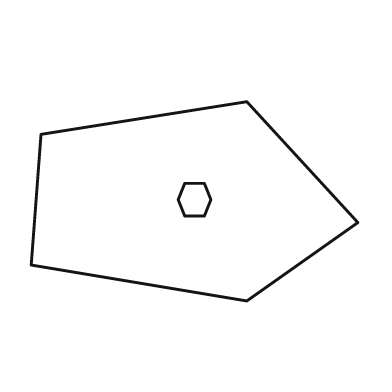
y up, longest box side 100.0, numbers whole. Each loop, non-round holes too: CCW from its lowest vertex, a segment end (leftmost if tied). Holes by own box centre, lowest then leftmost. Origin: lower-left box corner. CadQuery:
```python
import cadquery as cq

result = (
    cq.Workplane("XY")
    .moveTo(66.0, 0.0)
    .lineTo(100.0, 24.0)
    .lineTo(66.0, 61.0)
    .lineTo(3.0, 51.0)
    .lineTo(0.0, 11.0)
    .close()
    .moveTo(47.0, 26.0)
    .lineTo(53.0, 26.0)
    .lineTo(55.0, 31.0)
    .lineTo(53.0, 36.0)
    .lineTo(47.0, 36.0)
    .lineTo(45.0, 31.0)
    .close()
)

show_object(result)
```